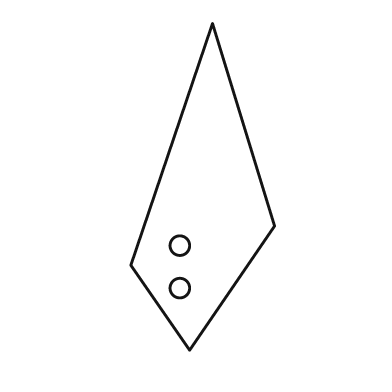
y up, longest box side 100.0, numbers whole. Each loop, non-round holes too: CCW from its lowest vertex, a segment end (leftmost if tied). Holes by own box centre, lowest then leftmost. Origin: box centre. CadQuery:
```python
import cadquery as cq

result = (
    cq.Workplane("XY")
    .moveTo(-4.0, -50.0)
    .lineTo(22.0, -12.0)
    .lineTo(3.0, 50.0)
    .lineTo(-22.0, -24.0)
    .close()
    .moveTo(-7.0, -31.0)
    .circle(3.0)
    .moveTo(-7.0, -18.0)
    .circle(3.0)
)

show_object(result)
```